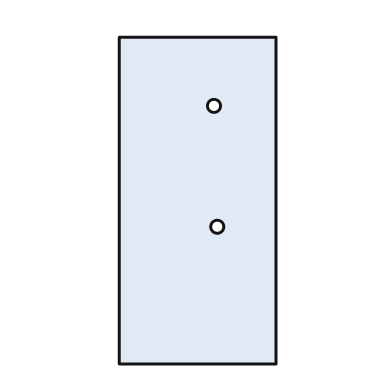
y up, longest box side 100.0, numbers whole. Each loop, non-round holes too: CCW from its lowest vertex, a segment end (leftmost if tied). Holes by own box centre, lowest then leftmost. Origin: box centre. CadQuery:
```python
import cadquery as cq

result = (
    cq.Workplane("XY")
    .moveTo(-24.0, -50.0)
    .lineTo(24.0, -50.0)
    .lineTo(24.0, 50.0)
    .lineTo(-24.0, 50.0)
    .close()
    .moveTo(6.0, -8.0)
    .circle(2.0)
    .moveTo(5.0, 29.0)
    .circle(2.0)
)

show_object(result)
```